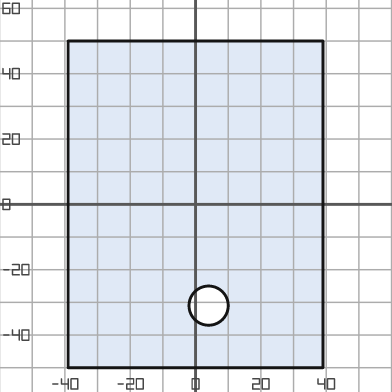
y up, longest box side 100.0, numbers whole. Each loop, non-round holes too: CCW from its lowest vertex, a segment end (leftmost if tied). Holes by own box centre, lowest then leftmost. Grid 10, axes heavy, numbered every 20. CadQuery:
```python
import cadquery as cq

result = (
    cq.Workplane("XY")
    .moveTo(-39.0, -50.0)
    .lineTo(39.0, -50.0)
    .lineTo(39.0, 50.0)
    .lineTo(-39.0, 50.0)
    .close()
    .moveTo(4.0, -31.0)
    .circle(6.0)
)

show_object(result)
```